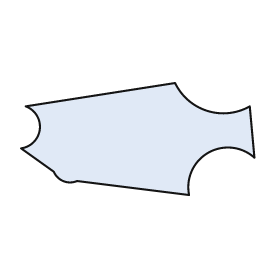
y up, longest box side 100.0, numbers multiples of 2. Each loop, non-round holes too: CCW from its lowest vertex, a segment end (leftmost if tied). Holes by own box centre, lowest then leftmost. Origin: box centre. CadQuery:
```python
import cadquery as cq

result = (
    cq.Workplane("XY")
    .moveTo(22.0, -24.0)
    .threePointArc((30.0, -6.0), (50.0, -8.0))
    .lineTo(48.0, 14.0)
    .threePointArc((30.0, 12.0), (16.0, 24.0))
    .lineTo(-48.0, 14.0)
    .threePointArc((-42.0, 4.0), (-50.0, -4.0))
    .lineTo(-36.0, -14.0)
    .threePointArc((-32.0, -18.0), (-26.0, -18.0))
    .close()
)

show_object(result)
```